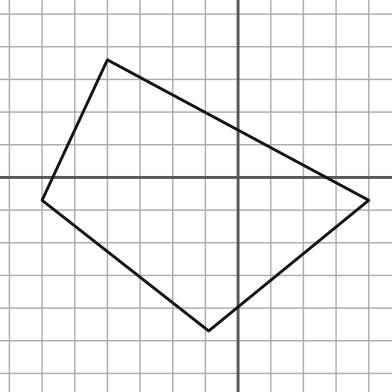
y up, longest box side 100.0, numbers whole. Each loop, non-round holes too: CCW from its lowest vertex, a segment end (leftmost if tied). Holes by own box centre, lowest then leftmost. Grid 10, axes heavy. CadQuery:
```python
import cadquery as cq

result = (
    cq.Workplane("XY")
    .moveTo(-9.0, -47.0)
    .lineTo(40.0, -7.0)
    .lineTo(-40.0, 36.0)
    .lineTo(-60.0, -7.0)
    .close()
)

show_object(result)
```